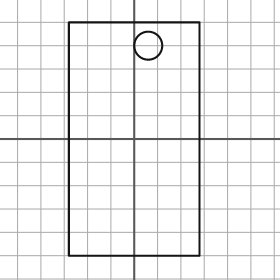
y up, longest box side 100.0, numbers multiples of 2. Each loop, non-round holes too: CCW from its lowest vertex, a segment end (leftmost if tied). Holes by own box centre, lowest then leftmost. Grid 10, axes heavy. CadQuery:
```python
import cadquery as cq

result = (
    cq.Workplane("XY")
    .moveTo(-28.0, -50.0)
    .lineTo(28.0, -50.0)
    .lineTo(28.0, 50.0)
    .lineTo(-28.0, 50.0)
    .close()
    .moveTo(6.0, 40.0)
    .circle(6.0)
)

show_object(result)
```